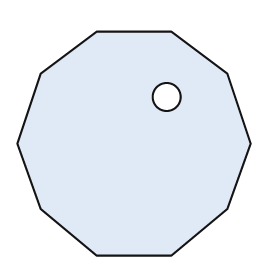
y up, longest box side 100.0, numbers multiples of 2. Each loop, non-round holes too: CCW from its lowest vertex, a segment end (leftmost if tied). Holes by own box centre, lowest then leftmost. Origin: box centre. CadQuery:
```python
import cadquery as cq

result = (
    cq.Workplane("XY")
    .moveTo(-16.0, -48.0)
    .lineTo(16.0, -48.0)
    .lineTo(40.0, -28.0)
    .lineTo(50.0, 0.0)
    .lineTo(40.0, 30.0)
    .lineTo(16.0, 48.0)
    .lineTo(-16.0, 48.0)
    .lineTo(-40.0, 30.0)
    .lineTo(-50.0, 0.0)
    .lineTo(-40.0, -28.0)
    .close()
    .moveTo(14.0, 20.0)
    .circle(6.0)
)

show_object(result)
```